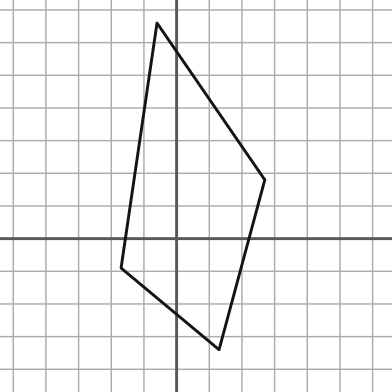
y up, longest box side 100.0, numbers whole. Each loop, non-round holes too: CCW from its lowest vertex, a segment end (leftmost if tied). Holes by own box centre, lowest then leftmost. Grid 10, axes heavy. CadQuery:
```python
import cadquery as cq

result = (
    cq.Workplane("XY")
    .moveTo(13.0, -34.0)
    .lineTo(27.0, 18.0)
    .lineTo(-6.0, 66.0)
    .lineTo(-17.0, -9.0)
    .close()
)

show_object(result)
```